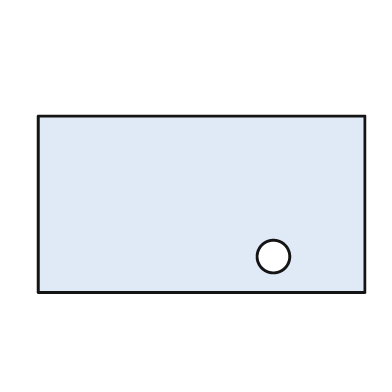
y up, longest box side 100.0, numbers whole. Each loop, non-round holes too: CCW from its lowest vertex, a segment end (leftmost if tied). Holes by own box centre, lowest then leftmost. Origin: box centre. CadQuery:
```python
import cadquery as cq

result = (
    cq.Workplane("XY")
    .moveTo(-50.0, -27.0)
    .lineTo(50.0, -27.0)
    .lineTo(50.0, 27.0)
    .lineTo(-50.0, 27.0)
    .close()
    .moveTo(22.0, -16.0)
    .circle(5.0)
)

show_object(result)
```